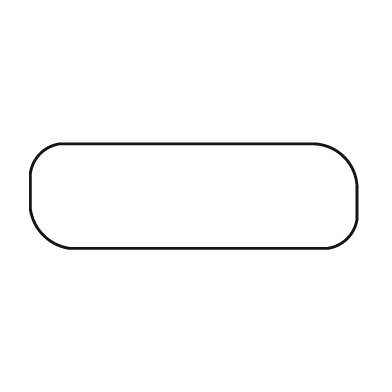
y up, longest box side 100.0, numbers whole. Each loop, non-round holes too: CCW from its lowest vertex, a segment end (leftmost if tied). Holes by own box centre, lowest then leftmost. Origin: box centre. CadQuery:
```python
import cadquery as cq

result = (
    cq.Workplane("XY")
    .moveTo(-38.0, -16.0)
    .lineTo(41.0, -16.0)
    .threePointArc((47.0, -13.0), (50.0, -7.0))
    .lineTo(50.0, 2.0)
    .threePointArc((46.0, 12.0), (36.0, 16.0))
    .lineTo(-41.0, 16.0)
    .threePointArc((-47.0, 13.0), (-50.0, 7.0))
    .lineTo(-50.0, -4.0)
    .threePointArc((-46.0, -12.0), (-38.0, -16.0))
    .close()
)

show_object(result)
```